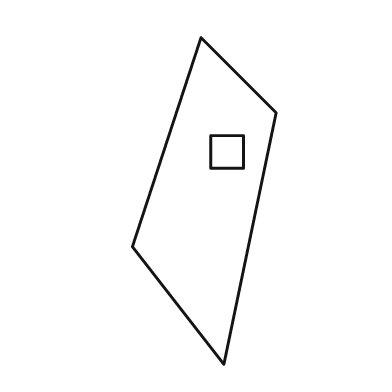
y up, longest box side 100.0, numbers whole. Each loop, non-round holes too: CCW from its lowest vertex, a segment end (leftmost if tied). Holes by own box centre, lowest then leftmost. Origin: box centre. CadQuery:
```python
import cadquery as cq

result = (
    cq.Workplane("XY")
    .moveTo(6.0, -50.0)
    .lineTo(22.0, 27.0)
    .lineTo(-1.0, 50.0)
    .lineTo(-22.0, -14.0)
    .close()
    .moveTo(2.0, 10.0)
    .lineTo(12.0, 10.0)
    .lineTo(12.0, 20.0)
    .lineTo(2.0, 20.0)
    .close()
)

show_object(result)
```